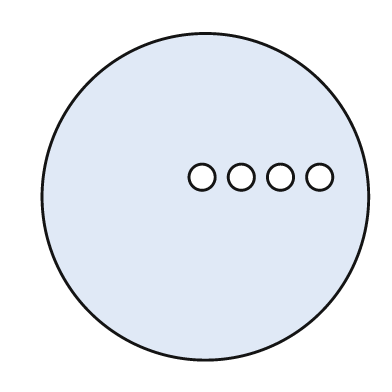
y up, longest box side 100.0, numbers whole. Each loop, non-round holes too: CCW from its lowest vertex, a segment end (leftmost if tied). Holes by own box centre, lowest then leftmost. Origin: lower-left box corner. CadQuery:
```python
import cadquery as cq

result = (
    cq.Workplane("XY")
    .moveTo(50.0, 50.0)
    .circle(50.0)
    .moveTo(49.0, 56.0)
    .circle(4.0)
    .moveTo(61.0, 56.0)
    .circle(4.0)
    .moveTo(73.0, 56.0)
    .circle(4.0)
    .moveTo(85.0, 56.0)
    .circle(4.0)
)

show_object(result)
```